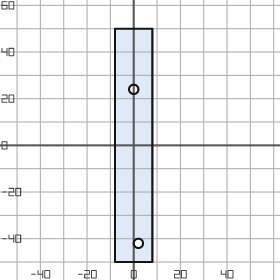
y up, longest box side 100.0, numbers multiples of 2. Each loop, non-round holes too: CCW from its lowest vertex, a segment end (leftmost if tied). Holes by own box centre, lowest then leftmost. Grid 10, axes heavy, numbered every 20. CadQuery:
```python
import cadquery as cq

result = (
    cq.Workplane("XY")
    .moveTo(-8.0, -50.0)
    .lineTo(8.0, -50.0)
    .lineTo(8.0, 50.0)
    .lineTo(-8.0, 50.0)
    .close()
    .moveTo(2.0, -42.0)
    .circle(2.0)
    .moveTo(0.0, 24.0)
    .circle(2.0)
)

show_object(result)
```